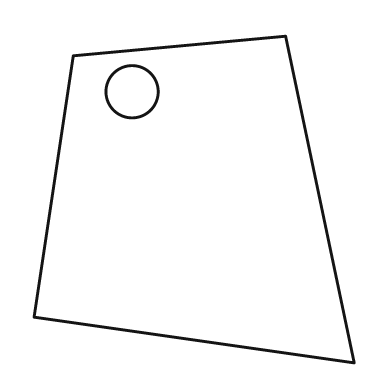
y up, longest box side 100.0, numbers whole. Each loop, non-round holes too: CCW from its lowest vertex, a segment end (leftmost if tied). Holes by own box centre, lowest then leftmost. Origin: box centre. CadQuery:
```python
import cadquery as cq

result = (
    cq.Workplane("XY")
    .moveTo(49.0, -50.0)
    .lineTo(28.0, 50.0)
    .lineTo(-37.0, 44.0)
    .lineTo(-49.0, -36.0)
    .close()
    .moveTo(-19.0, 33.0)
    .circle(8.0)
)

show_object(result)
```